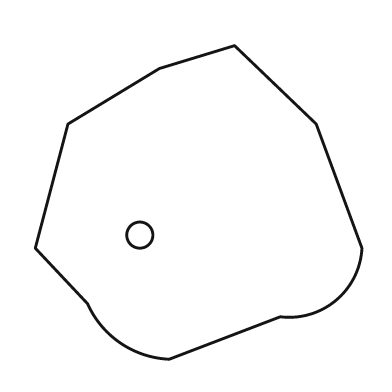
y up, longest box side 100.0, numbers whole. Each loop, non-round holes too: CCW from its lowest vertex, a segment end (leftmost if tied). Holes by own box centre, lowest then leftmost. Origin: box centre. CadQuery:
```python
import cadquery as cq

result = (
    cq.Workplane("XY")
    .moveTo(-9.0, -48.0)
    .lineTo(25.0, -35.0)
    .threePointArc((42.0, -30.0), (50.0, -14.0))
    .lineTo(36.0, 24.0)
    .lineTo(11.0, 48.0)
    .lineTo(-12.0, 41.0)
    .lineTo(-40.0, 24.0)
    .lineTo(-50.0, -14.0)
    .lineTo(-34.0, -31.0)
    .threePointArc((-24.0, -43.0), (-9.0, -48.0))
    .close()
    .moveTo(-18.0, -10.0)
    .circle(4.0)
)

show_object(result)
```